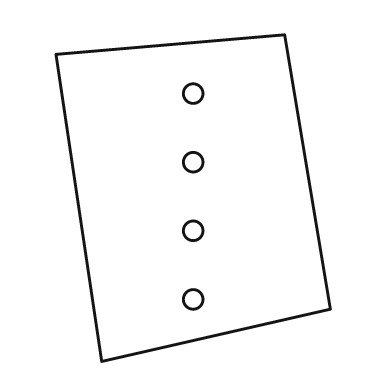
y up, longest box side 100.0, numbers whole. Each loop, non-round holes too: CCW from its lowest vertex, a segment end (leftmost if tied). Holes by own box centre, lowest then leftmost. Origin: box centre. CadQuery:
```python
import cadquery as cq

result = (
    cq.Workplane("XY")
    .moveTo(-28.0, -50.0)
    .lineTo(42.0, -34.0)
    .lineTo(28.0, 50.0)
    .lineTo(-42.0, 44.0)
    .close()
    .moveTo(0.0, -31.0)
    .circle(3.0)
    .moveTo(0.0, -10.0)
    .circle(3.0)
    .moveTo(0.0, 11.0)
    .circle(3.0)
    .moveTo(0.0, 32.0)
    .circle(3.0)
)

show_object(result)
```